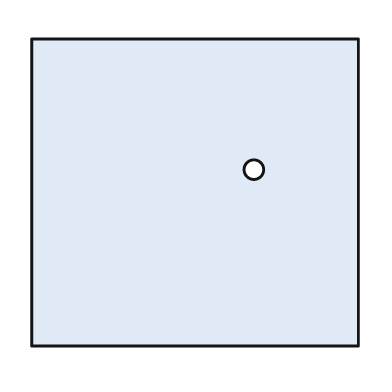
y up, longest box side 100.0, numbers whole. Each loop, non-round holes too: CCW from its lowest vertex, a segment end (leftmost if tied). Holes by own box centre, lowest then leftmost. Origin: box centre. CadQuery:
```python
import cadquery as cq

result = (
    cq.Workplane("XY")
    .moveTo(-50.0, -47.0)
    .lineTo(50.0, -47.0)
    .lineTo(50.0, 47.0)
    .lineTo(-50.0, 47.0)
    .close()
    .moveTo(18.0, 7.0)
    .circle(3.0)
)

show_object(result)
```